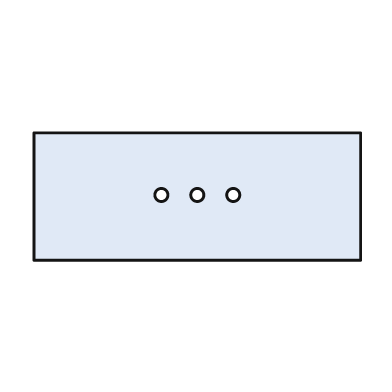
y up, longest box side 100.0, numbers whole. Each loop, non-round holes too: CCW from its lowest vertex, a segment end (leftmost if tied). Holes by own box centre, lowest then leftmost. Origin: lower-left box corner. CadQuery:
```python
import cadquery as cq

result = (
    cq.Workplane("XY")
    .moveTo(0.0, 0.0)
    .lineTo(100.0, 0.0)
    .lineTo(100.0, 39.0)
    .lineTo(0.0, 39.0)
    .close()
    .moveTo(39.0, 20.0)
    .circle(2.0)
    .moveTo(50.0, 20.0)
    .circle(2.0)
    .moveTo(61.0, 20.0)
    .circle(2.0)
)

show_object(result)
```